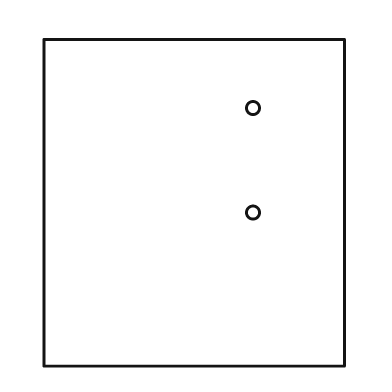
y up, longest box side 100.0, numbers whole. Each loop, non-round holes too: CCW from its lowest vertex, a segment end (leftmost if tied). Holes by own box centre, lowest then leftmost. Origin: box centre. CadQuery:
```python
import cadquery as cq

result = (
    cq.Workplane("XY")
    .moveTo(-46.0, -50.0)
    .lineTo(46.0, -50.0)
    .lineTo(46.0, 50.0)
    .lineTo(-46.0, 50.0)
    .close()
    .moveTo(18.0, -3.0)
    .circle(2.0)
    .moveTo(18.0, 29.0)
    .circle(2.0)
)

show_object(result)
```